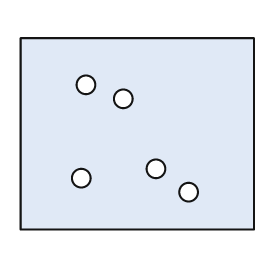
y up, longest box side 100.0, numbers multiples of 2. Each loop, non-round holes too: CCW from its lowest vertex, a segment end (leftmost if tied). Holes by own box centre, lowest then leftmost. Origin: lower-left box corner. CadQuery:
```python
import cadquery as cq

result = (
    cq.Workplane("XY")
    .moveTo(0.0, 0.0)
    .lineTo(100.0, 0.0)
    .lineTo(100.0, 82.0)
    .lineTo(0.0, 82.0)
    .close()
    .moveTo(72.0, 16.0)
    .circle(4.0)
    .moveTo(26.0, 22.0)
    .circle(4.0)
    .moveTo(58.0, 26.0)
    .circle(4.0)
    .moveTo(44.0, 56.0)
    .circle(4.0)
    .moveTo(28.0, 62.0)
    .circle(4.0)
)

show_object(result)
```